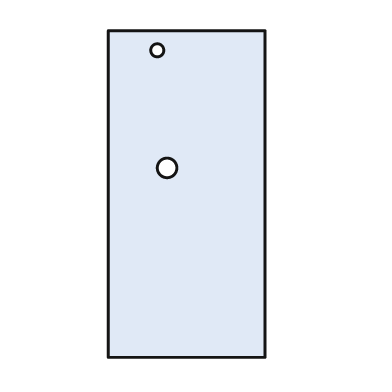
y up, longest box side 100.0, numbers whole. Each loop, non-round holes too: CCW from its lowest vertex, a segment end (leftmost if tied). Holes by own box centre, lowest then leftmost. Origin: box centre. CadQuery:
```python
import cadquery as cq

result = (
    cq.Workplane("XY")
    .moveTo(-24.0, -50.0)
    .lineTo(24.0, -50.0)
    .lineTo(24.0, 50.0)
    .lineTo(-24.0, 50.0)
    .close()
    .moveTo(-6.0, 8.0)
    .circle(3.0)
    .moveTo(-9.0, 44.0)
    .circle(2.0)
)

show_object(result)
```